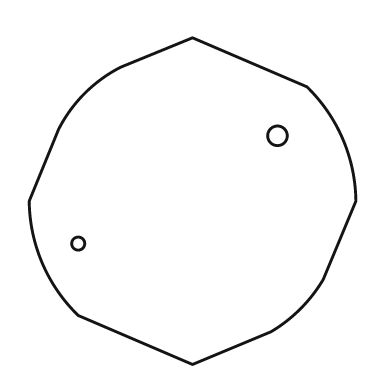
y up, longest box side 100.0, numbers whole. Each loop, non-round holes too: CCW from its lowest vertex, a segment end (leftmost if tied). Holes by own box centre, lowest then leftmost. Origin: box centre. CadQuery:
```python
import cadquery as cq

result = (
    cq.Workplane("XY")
    .moveTo(0.0, -50.0)
    .lineTo(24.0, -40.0)
    .threePointArc((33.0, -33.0), (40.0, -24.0))
    .lineTo(50.0, 0.0)
    .threePointArc((46.0, 19.0), (35.0, 35.0))
    .lineTo(0.0, 50.0)
    .lineTo(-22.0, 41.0)
    .threePointArc((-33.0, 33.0), (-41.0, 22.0))
    .lineTo(-50.0, 0.0)
    .threePointArc((-46.0, -19.0), (-35.0, -35.0))
    .close()
    .moveTo(-35.0, -13.0)
    .circle(2.0)
    .moveTo(26.0, 20.0)
    .circle(3.0)
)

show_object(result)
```